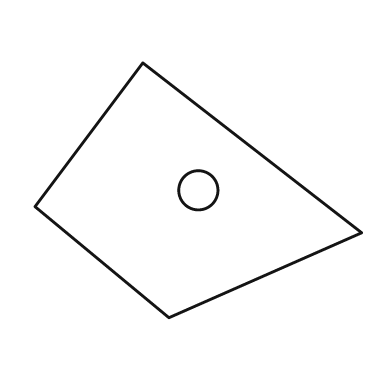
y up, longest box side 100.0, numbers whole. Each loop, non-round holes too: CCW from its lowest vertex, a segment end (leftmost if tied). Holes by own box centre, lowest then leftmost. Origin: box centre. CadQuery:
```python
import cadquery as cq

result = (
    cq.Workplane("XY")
    .moveTo(-9.0, -39.0)
    .lineTo(50.0, -13.0)
    .lineTo(-17.0, 39.0)
    .lineTo(-50.0, -5.0)
    .close()
    .moveTo(0.0, 0.0)
    .circle(6.0)
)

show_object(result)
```